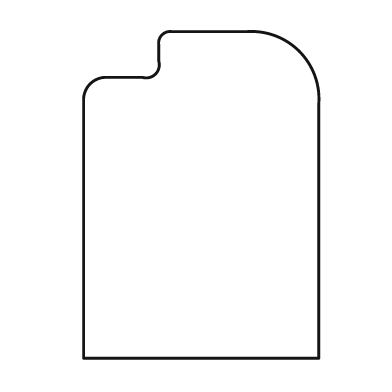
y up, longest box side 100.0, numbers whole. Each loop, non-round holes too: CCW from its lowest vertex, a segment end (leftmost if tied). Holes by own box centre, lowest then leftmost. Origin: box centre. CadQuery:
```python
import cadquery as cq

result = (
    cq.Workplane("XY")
    .moveTo(-36.0, -50.0)
    .lineTo(36.0, -50.0)
    .lineTo(36.0, 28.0)
    .threePointArc((30.0, 44.0), (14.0, 50.0))
    .lineTo(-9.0, 50.0)
    .threePointArc((-12.0, 49.0), (-13.0, 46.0))
    .lineTo(-13.0, 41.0)
    .threePointArc((-14.0, 37.0), (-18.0, 36.0))
    .lineTo(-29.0, 36.0)
    .threePointArc((-34.0, 34.0), (-36.0, 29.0))
    .close()
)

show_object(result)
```